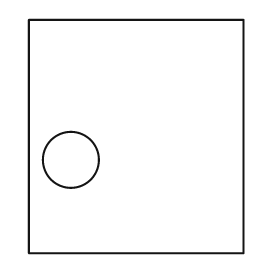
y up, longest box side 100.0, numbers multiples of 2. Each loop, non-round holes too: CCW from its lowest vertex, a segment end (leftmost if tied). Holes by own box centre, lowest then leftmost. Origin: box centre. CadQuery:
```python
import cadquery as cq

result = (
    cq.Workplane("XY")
    .moveTo(-46.0, -50.0)
    .lineTo(46.0, -50.0)
    .lineTo(46.0, 50.0)
    .lineTo(-46.0, 50.0)
    .close()
    .moveTo(-28.0, -10.0)
    .circle(12.0)
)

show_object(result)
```